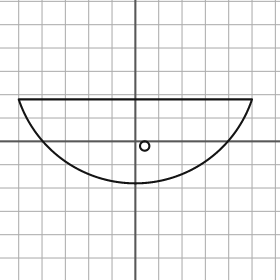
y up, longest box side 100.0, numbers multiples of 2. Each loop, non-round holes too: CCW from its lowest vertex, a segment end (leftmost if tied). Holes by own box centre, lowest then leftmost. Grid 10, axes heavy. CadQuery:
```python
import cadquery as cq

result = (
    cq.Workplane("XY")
    .moveTo(-50.0, 18.0)
    .threePointArc((0.0, -18.0), (50.0, 18.0))
    .close()
    .moveTo(4.0, -2.0)
    .circle(2.0)
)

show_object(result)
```